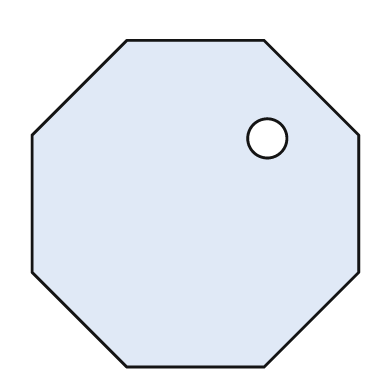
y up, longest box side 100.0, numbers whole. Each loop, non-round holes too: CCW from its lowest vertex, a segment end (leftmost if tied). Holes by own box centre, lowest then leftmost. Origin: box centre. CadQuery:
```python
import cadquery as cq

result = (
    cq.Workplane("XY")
    .moveTo(-21.0, -50.0)
    .lineTo(21.0, -50.0)
    .lineTo(50.0, -21.0)
    .lineTo(50.0, 21.0)
    .lineTo(21.0, 50.0)
    .lineTo(-21.0, 50.0)
    .lineTo(-50.0, 21.0)
    .lineTo(-50.0, -21.0)
    .close()
    .moveTo(22.0, 20.0)
    .circle(6.0)
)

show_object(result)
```